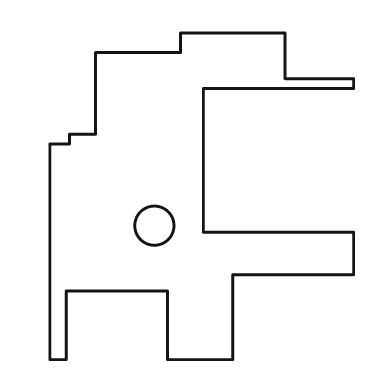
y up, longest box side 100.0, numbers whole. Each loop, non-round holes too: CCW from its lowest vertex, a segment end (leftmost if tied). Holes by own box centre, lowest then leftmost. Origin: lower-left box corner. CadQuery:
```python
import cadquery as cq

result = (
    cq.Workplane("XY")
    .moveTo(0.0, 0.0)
    .lineTo(5.0, 0.0)
    .lineTo(5.0, 21.0)
    .lineTo(36.0, 21.0)
    .lineTo(36.0, 0.0)
    .lineTo(56.0, 0.0)
    .lineTo(56.0, 26.0)
    .lineTo(93.0, 26.0)
    .lineTo(93.0, 39.0)
    .lineTo(47.0, 39.0)
    .lineTo(47.0, 83.0)
    .lineTo(93.0, 83.0)
    .lineTo(93.0, 86.0)
    .lineTo(72.0, 86.0)
    .lineTo(72.0, 100.0)
    .lineTo(40.0, 100.0)
    .lineTo(40.0, 94.0)
    .lineTo(14.0, 94.0)
    .lineTo(14.0, 69.0)
    .lineTo(6.0, 69.0)
    .lineTo(6.0, 66.0)
    .lineTo(0.0, 66.0)
    .close()
    .moveTo(32.0, 41.0)
    .circle(6.0)
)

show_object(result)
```